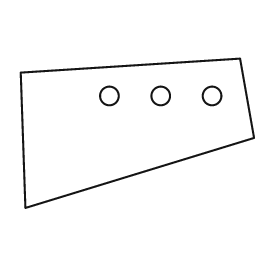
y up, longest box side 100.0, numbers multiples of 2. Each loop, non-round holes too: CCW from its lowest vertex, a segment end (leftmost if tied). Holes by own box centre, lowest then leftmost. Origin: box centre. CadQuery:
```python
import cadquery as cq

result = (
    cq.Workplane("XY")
    .moveTo(-48.0, -32.0)
    .lineTo(50.0, -2.0)
    .lineTo(44.0, 32.0)
    .lineTo(-50.0, 26.0)
    .close()
    .moveTo(-12.0, 16.0)
    .circle(4.0)
    .moveTo(10.0, 16.0)
    .circle(4.0)
    .moveTo(32.0, 16.0)
    .circle(4.0)
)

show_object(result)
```